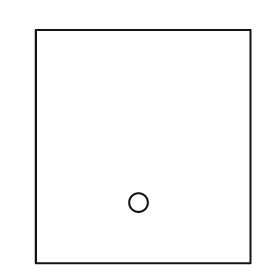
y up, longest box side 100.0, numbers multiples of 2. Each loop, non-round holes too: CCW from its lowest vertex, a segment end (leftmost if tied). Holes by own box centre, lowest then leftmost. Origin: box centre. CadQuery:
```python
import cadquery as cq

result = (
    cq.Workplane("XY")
    .moveTo(-46.0, -50.0)
    .lineTo(46.0, -50.0)
    .lineTo(46.0, 50.0)
    .lineTo(-46.0, 50.0)
    .close()
    .moveTo(-2.0, -24.0)
    .circle(4.0)
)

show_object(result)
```